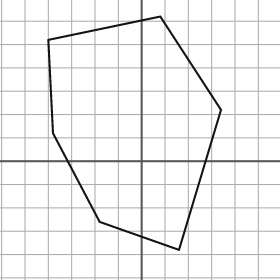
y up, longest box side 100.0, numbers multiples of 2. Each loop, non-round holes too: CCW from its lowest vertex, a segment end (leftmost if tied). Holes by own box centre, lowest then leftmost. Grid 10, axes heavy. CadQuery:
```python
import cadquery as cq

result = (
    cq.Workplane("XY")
    .moveTo(16.0, -38.0)
    .lineTo(34.0, 22.0)
    .lineTo(8.0, 62.0)
    .lineTo(-40.0, 52.0)
    .lineTo(-38.0, 12.0)
    .lineTo(-18.0, -26.0)
    .close()
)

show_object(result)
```